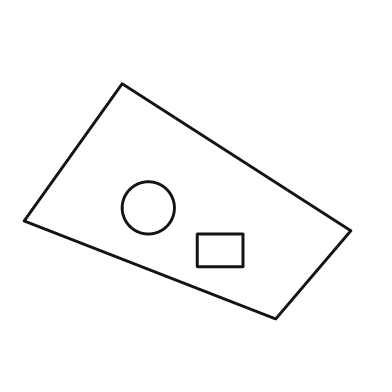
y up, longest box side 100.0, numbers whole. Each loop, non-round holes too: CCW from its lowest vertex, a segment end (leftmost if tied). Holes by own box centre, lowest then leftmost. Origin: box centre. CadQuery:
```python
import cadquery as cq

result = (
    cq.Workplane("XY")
    .moveTo(27.0, -36.0)
    .lineTo(50.0, -9.0)
    .lineTo(-20.0, 36.0)
    .lineTo(-50.0, -6.0)
    .close()
    .moveTo(3.0, -20.0)
    .lineTo(17.0, -20.0)
    .lineTo(17.0, -10.0)
    .lineTo(3.0, -10.0)
    .close()
    .moveTo(-12.0, -2.0)
    .circle(8.0)
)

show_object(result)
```